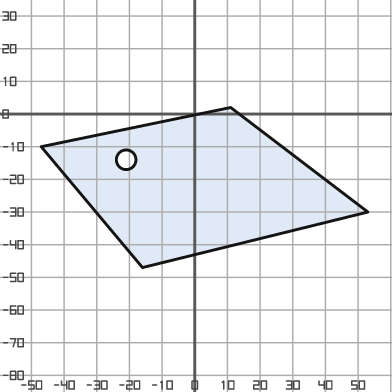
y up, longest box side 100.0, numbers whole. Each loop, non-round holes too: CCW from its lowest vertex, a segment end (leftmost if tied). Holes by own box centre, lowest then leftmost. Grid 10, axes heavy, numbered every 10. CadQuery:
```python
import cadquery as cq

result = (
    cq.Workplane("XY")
    .moveTo(-16.0, -47.0)
    .lineTo(53.0, -30.0)
    .lineTo(11.0, 2.0)
    .lineTo(-47.0, -10.0)
    .close()
    .moveTo(-21.0, -14.0)
    .circle(3.0)
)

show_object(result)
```